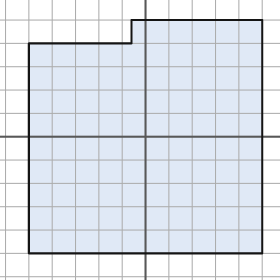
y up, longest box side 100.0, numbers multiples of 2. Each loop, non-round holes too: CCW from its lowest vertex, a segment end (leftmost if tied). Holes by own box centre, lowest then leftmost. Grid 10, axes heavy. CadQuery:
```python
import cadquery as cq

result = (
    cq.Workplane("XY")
    .moveTo(-50.0, -50.0)
    .lineTo(50.0, -50.0)
    .lineTo(50.0, 50.0)
    .lineTo(-6.0, 50.0)
    .lineTo(-6.0, 40.0)
    .lineTo(-50.0, 40.0)
    .close()
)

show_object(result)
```